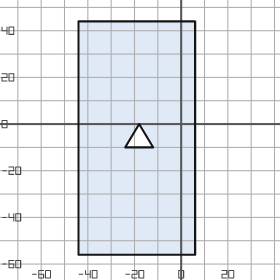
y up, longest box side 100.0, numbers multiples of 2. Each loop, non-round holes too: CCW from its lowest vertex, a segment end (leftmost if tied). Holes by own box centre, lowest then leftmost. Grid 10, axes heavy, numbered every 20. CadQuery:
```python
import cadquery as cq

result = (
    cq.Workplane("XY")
    .moveTo(-44.0, -56.0)
    .lineTo(6.0, -56.0)
    .lineTo(6.0, 44.0)
    .lineTo(-44.0, 44.0)
    .close()
    .moveTo(-24.0, -10.0)
    .lineTo(-12.0, -10.0)
    .lineTo(-18.0, 0.0)
    .close()
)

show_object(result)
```